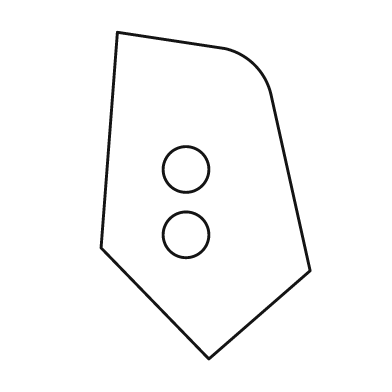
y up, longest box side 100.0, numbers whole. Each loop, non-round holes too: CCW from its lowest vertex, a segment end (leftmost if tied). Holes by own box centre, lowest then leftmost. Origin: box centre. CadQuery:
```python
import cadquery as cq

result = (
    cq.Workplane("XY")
    .moveTo(1.0, -50.0)
    .lineTo(32.0, -23.0)
    .lineTo(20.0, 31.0)
    .threePointArc((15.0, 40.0), (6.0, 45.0))
    .lineTo(-27.0, 50.0)
    .lineTo(-32.0, -16.0)
    .close()
    .moveTo(-6.0, -12.0)
    .circle(7.0)
    .moveTo(-6.0, 8.0)
    .circle(7.0)
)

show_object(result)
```